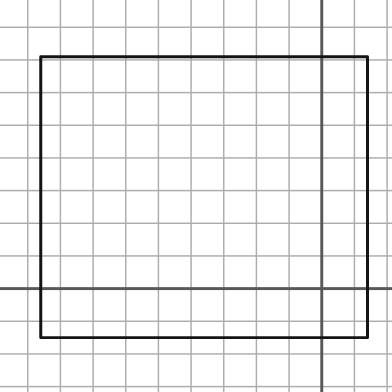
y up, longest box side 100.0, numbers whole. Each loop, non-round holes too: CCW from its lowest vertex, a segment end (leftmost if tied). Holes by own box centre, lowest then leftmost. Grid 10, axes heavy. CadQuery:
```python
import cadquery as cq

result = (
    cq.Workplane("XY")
    .moveTo(-86.0, -15.0)
    .lineTo(14.0, -15.0)
    .lineTo(14.0, 71.0)
    .lineTo(-86.0, 71.0)
    .close()
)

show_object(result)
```